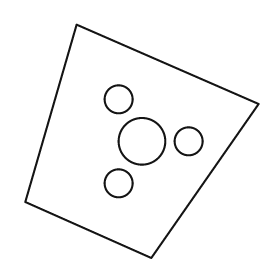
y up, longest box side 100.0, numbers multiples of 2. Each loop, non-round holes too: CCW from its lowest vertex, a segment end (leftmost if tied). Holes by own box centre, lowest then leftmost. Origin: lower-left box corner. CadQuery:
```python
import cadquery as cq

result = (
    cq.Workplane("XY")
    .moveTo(54.0, 0.0)
    .lineTo(100.0, 66.0)
    .lineTo(22.0, 100.0)
    .lineTo(0.0, 24.0)
    .close()
    .moveTo(40.0, 32.0)
    .circle(6.0)
    .moveTo(50.0, 50.0)
    .circle(10.0)
    .moveTo(70.0, 50.0)
    .circle(6.0)
    .moveTo(40.0, 68.0)
    .circle(6.0)
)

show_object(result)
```